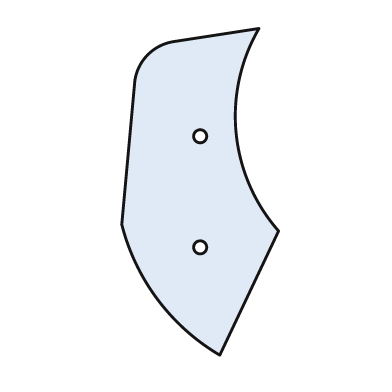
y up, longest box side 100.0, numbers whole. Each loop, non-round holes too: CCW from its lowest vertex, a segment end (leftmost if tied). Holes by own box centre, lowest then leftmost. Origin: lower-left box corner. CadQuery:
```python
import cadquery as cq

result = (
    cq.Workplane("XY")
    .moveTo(30.0, 0.0)
    .lineTo(48.0, 38.0)
    .threePointArc((35.0, 68.0), (42.0, 100.0))
    .lineTo(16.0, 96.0)
    .threePointArc((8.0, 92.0), (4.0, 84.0))
    .lineTo(0.0, 40.0)
    .threePointArc((11.0, 17.0), (30.0, 0.0))
    .close()
    .moveTo(24.0, 33.0)
    .circle(2.0)
    .moveTo(24.0, 67.0)
    .circle(2.0)
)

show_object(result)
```